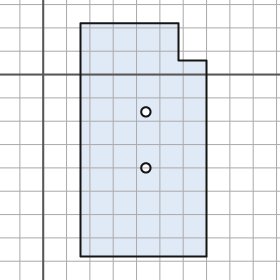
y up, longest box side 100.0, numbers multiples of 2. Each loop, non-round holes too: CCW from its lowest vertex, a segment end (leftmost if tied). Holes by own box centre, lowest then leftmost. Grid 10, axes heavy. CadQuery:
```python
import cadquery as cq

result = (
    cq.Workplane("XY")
    .moveTo(16.0, -78.0)
    .lineTo(70.0, -78.0)
    .lineTo(70.0, 6.0)
    .lineTo(58.0, 6.0)
    .lineTo(58.0, 22.0)
    .lineTo(16.0, 22.0)
    .close()
    .moveTo(44.0, -40.0)
    .circle(2.0)
    .moveTo(44.0, -16.0)
    .circle(2.0)
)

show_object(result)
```